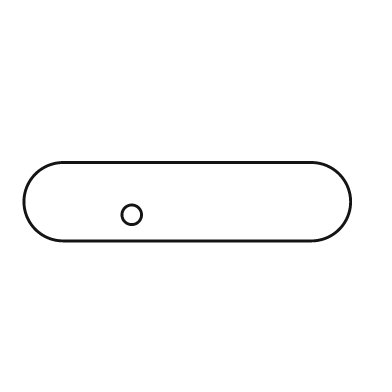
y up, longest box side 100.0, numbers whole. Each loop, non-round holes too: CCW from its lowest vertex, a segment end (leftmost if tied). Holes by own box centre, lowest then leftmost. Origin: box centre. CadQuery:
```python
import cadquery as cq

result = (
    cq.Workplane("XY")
    .moveTo(-38.0, -12.0)
    .lineTo(38.0, -12.0)
    .threePointArc((50.0, 0.0), (38.0, 12.0))
    .lineTo(-38.0, 12.0)
    .threePointArc((-50.0, 0.0), (-38.0, -12.0))
    .close()
    .moveTo(-17.0, -4.0)
    .circle(3.0)
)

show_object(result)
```